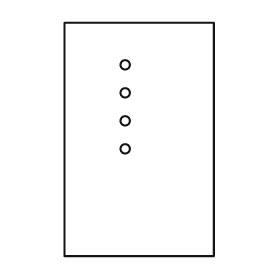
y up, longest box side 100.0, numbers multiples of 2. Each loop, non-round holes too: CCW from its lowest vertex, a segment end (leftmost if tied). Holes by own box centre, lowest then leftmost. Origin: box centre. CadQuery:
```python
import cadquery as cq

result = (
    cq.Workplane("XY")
    .moveTo(-32.0, -50.0)
    .lineTo(32.0, -50.0)
    .lineTo(32.0, 50.0)
    .lineTo(-32.0, 50.0)
    .close()
    .moveTo(-6.0, -4.0)
    .circle(2.0)
    .moveTo(-6.0, 8.0)
    .circle(2.0)
    .moveTo(-6.0, 20.0)
    .circle(2.0)
    .moveTo(-6.0, 32.0)
    .circle(2.0)
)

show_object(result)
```